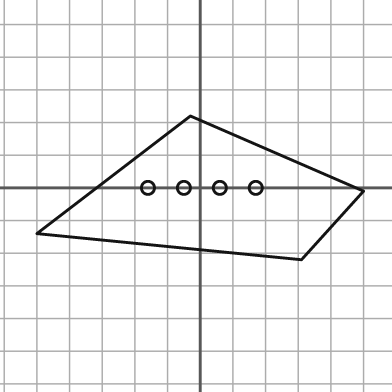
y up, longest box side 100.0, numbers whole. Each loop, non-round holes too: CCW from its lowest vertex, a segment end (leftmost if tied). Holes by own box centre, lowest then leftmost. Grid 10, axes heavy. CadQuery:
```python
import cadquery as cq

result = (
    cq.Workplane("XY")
    .moveTo(31.0, -22.0)
    .lineTo(50.0, -1.0)
    .lineTo(-3.0, 22.0)
    .lineTo(-50.0, -14.0)
    .close()
    .moveTo(-16.0, 0.0)
    .circle(2.0)
    .moveTo(-5.0, 0.0)
    .circle(2.0)
    .moveTo(6.0, 0.0)
    .circle(2.0)
    .moveTo(17.0, 0.0)
    .circle(2.0)
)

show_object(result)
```